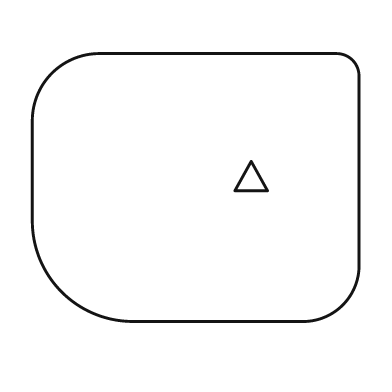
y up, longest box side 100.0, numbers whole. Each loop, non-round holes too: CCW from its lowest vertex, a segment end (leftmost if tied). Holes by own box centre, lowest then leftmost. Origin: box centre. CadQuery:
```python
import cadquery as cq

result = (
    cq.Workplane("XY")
    .moveTo(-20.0, -41.0)
    .lineTo(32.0, -41.0)
    .threePointArc((45.0, -36.0), (50.0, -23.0))
    .lineTo(50.0, 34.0)
    .threePointArc((48.0, 39.0), (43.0, 41.0))
    .lineTo(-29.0, 41.0)
    .threePointArc((-44.0, 35.0), (-50.0, 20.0))
    .lineTo(-50.0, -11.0)
    .threePointArc((-41.0, -32.0), (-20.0, -41.0))
    .close()
    .moveTo(12.0, -1.0)
    .lineTo(22.0, -1.0)
    .lineTo(17.0, 8.0)
    .close()
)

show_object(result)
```